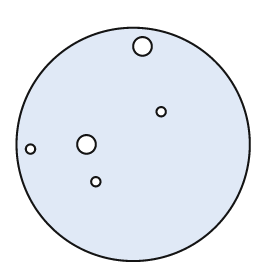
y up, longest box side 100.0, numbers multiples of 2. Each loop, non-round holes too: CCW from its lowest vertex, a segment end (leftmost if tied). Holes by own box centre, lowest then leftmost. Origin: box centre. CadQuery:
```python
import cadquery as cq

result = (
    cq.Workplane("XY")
    .moveTo(0.0, 0.0)
    .circle(50.0)
    .moveTo(-16.0, -16.0)
    .circle(2.0)
    .moveTo(-44.0, -2.0)
    .circle(2.0)
    .moveTo(-20.0, 0.0)
    .circle(4.0)
    .moveTo(12.0, 14.0)
    .circle(2.0)
    .moveTo(4.0, 42.0)
    .circle(4.0)
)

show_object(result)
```